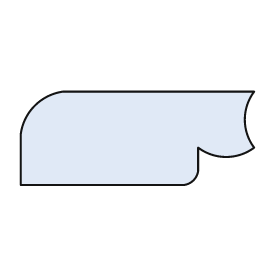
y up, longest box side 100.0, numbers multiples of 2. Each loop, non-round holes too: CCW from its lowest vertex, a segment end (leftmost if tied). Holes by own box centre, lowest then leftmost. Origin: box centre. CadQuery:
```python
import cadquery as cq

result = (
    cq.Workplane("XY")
    .moveTo(-50.0, -20.0)
    .lineTo(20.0, -20.0)
    .threePointArc((24.0, -18.0), (26.0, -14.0))
    .lineTo(26.0, -4.0)
    .threePointArc((38.0, -8.0), (50.0, -4.0))
    .threePointArc((46.0, 8.0), (50.0, 20.0))
    .lineTo(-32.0, 20.0)
    .threePointArc((-44.0, 14.0), (-50.0, 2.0))
    .close()
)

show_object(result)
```